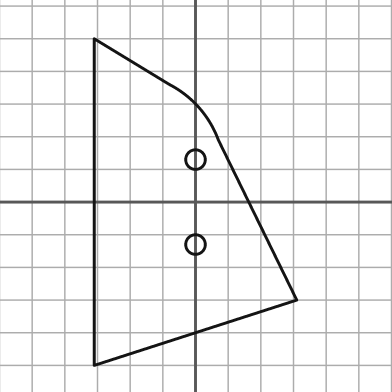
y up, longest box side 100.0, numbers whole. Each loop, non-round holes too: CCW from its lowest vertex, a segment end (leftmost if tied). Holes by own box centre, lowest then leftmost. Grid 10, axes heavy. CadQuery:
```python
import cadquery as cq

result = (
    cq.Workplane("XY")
    .moveTo(-31.0, -50.0)
    .lineTo(31.0, -30.0)
    .lineTo(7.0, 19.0)
    .threePointArc((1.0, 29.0), (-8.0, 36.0))
    .lineTo(-31.0, 50.0)
    .close()
    .moveTo(0.0, -13.0)
    .circle(3.0)
    .moveTo(0.0, 13.0)
    .circle(3.0)
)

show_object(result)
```